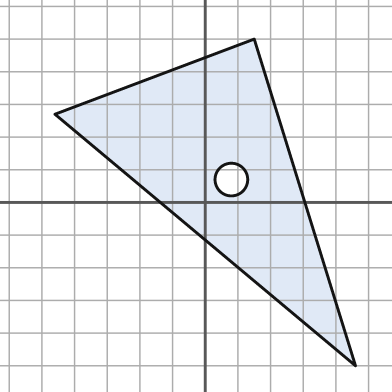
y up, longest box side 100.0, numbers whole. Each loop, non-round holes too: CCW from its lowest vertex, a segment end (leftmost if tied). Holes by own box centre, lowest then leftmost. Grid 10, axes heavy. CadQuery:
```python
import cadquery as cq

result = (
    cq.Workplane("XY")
    .moveTo(46.0, -50.0)
    .lineTo(15.0, 50.0)
    .lineTo(-46.0, 27.0)
    .close()
    .moveTo(8.0, 7.0)
    .circle(5.0)
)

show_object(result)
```